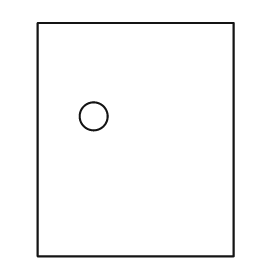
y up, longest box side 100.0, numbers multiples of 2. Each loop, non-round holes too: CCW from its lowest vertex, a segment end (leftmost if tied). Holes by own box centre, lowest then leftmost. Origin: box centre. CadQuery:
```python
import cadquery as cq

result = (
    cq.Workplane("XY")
    .moveTo(-42.0, -50.0)
    .lineTo(42.0, -50.0)
    .lineTo(42.0, 50.0)
    .lineTo(-42.0, 50.0)
    .close()
    .moveTo(-18.0, 10.0)
    .circle(6.0)
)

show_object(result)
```